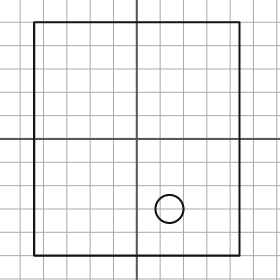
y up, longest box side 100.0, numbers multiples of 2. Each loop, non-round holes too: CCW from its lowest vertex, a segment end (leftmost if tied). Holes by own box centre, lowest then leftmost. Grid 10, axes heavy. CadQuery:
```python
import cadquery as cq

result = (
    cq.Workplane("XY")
    .moveTo(-44.0, -50.0)
    .lineTo(44.0, -50.0)
    .lineTo(44.0, 50.0)
    .lineTo(-44.0, 50.0)
    .close()
    .moveTo(14.0, -30.0)
    .circle(6.0)
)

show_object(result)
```